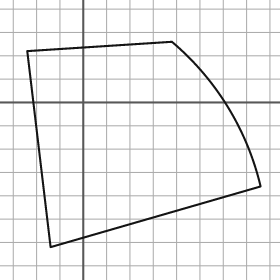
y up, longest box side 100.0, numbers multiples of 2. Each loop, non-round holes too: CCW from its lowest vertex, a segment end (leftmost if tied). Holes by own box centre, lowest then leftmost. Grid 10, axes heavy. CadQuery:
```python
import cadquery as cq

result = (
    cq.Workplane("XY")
    .moveTo(-14.0, -62.0)
    .lineTo(76.0, -36.0)
    .threePointArc((62.0, -2.0), (38.0, 26.0))
    .lineTo(-24.0, 22.0)
    .close()
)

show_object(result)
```